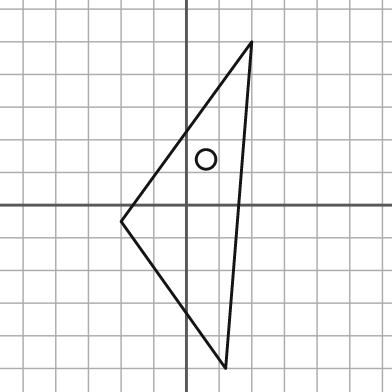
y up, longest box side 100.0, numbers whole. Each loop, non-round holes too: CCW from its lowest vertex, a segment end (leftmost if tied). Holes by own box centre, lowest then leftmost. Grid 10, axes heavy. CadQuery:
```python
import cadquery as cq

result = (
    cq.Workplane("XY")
    .moveTo(12.0, -50.0)
    .lineTo(20.0, 50.0)
    .lineTo(-20.0, -5.0)
    .close()
    .moveTo(6.0, 14.0)
    .circle(3.0)
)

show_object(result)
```